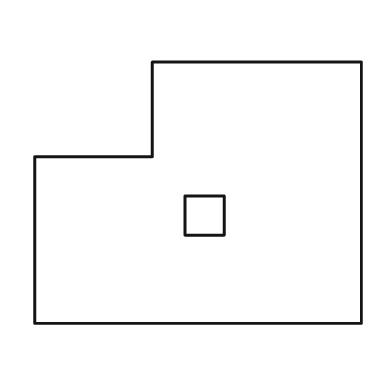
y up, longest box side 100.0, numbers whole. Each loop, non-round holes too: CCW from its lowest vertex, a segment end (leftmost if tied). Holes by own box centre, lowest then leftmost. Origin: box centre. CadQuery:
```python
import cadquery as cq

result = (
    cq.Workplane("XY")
    .moveTo(-50.0, -40.0)
    .lineTo(50.0, -40.0)
    .lineTo(50.0, 40.0)
    .lineTo(-14.0, 40.0)
    .lineTo(-14.0, 11.0)
    .lineTo(-50.0, 11.0)
    .close()
    .moveTo(-4.0, -13.0)
    .lineTo(8.0, -13.0)
    .lineTo(8.0, -1.0)
    .lineTo(-4.0, -1.0)
    .close()
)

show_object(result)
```